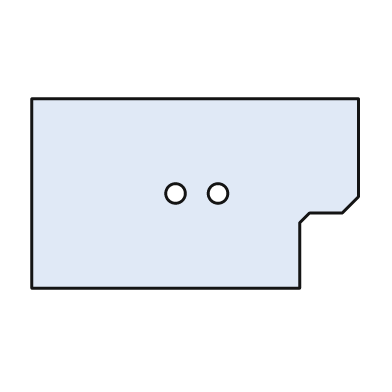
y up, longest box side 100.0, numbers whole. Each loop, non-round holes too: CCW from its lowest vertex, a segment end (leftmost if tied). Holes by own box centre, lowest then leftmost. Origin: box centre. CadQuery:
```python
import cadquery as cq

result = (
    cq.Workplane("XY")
    .moveTo(-50.0, -29.0)
    .lineTo(32.0, -29.0)
    .lineTo(32.0, -9.0)
    .lineTo(35.0, -6.0)
    .lineTo(45.0, -6.0)
    .lineTo(50.0, -1.0)
    .lineTo(50.0, 29.0)
    .lineTo(-50.0, 29.0)
    .close()
    .moveTo(-6.0, 0.0)
    .circle(3.0)
    .moveTo(7.0, 0.0)
    .circle(3.0)
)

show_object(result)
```